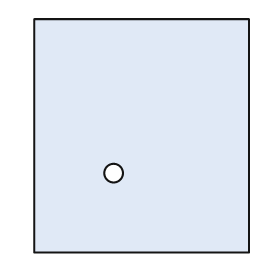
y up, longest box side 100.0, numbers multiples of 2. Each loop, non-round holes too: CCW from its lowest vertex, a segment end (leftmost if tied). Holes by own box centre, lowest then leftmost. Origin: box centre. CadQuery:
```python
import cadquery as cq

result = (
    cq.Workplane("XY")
    .moveTo(-46.0, -50.0)
    .lineTo(46.0, -50.0)
    .lineTo(46.0, 50.0)
    .lineTo(-46.0, 50.0)
    .close()
    .moveTo(-12.0, -16.0)
    .circle(4.0)
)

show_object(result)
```